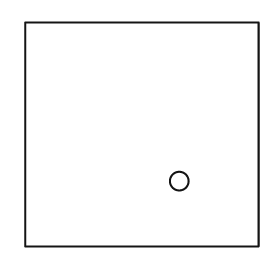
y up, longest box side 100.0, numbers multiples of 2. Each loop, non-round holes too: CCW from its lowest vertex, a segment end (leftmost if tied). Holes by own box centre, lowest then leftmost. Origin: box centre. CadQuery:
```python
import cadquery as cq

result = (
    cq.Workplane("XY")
    .moveTo(-50.0, -48.0)
    .lineTo(50.0, -48.0)
    .lineTo(50.0, 48.0)
    .lineTo(-50.0, 48.0)
    .close()
    .moveTo(16.0, -20.0)
    .circle(4.0)
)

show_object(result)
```